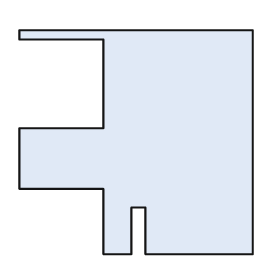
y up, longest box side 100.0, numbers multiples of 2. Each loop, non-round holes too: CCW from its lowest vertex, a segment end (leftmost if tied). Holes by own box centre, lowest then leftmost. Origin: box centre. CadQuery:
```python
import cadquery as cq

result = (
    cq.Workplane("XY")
    .moveTo(-14.0, -48.0)
    .lineTo(-2.0, -48.0)
    .lineTo(-2.0, -28.0)
    .lineTo(4.0, -28.0)
    .lineTo(4.0, -48.0)
    .lineTo(50.0, -48.0)
    .lineTo(50.0, 48.0)
    .lineTo(-50.0, 48.0)
    .lineTo(-50.0, 44.0)
    .lineTo(-14.0, 44.0)
    .lineTo(-14.0, 6.0)
    .lineTo(-50.0, 6.0)
    .lineTo(-50.0, -20.0)
    .lineTo(-14.0, -20.0)
    .close()
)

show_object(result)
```